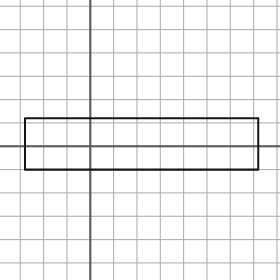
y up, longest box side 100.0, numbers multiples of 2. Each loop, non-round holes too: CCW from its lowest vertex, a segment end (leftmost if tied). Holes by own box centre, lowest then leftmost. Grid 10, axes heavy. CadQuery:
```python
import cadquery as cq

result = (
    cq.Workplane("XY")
    .moveTo(-28.0, -10.0)
    .lineTo(72.0, -10.0)
    .lineTo(72.0, 12.0)
    .lineTo(-28.0, 12.0)
    .close()
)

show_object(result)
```